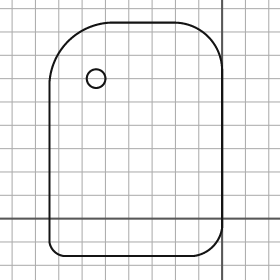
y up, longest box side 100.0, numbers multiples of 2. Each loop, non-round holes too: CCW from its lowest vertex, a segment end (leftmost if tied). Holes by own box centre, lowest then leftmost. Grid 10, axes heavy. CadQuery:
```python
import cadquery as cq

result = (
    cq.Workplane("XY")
    .moveTo(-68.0, -16.0)
    .lineTo(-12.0, -16.0)
    .threePointArc((-4.0, -12.0), (0.0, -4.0))
    .lineTo(0.0, 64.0)
    .threePointArc((-6.0, 78.0), (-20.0, 84.0))
    .lineTo(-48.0, 84.0)
    .threePointArc((-66.0, 76.0), (-74.0, 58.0))
    .lineTo(-74.0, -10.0)
    .threePointArc((-72.0, -14.0), (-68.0, -16.0))
    .close()
    .moveTo(-54.0, 60.0)
    .circle(4.0)
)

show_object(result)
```